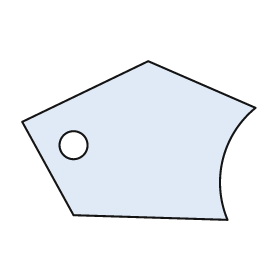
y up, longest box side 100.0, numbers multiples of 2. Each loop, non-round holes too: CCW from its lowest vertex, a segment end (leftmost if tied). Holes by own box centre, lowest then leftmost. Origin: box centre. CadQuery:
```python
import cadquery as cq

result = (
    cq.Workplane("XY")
    .moveTo(38.0, -34.0)
    .threePointArc((36.0, -8.0), (50.0, 14.0))
    .lineTo(4.0, 34.0)
    .lineTo(-50.0, 8.0)
    .lineTo(-28.0, -32.0)
    .close()
    .moveTo(-28.0, -2.0)
    .circle(6.0)
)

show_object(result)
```